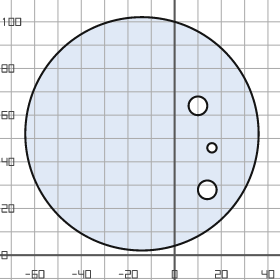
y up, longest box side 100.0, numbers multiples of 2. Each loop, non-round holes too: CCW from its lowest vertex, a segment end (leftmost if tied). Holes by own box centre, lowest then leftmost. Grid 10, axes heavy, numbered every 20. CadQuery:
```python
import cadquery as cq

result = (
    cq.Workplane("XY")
    .moveTo(-14.0, 52.0)
    .circle(50.0)
    .moveTo(14.0, 28.0)
    .circle(4.0)
    .moveTo(16.0, 46.0)
    .circle(2.0)
    .moveTo(10.0, 64.0)
    .circle(4.0)
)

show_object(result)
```